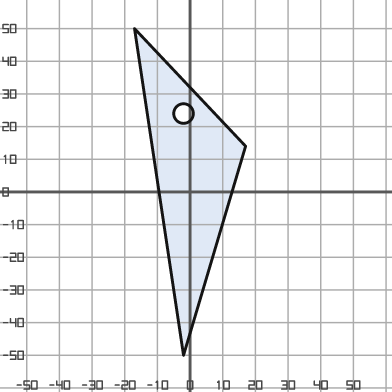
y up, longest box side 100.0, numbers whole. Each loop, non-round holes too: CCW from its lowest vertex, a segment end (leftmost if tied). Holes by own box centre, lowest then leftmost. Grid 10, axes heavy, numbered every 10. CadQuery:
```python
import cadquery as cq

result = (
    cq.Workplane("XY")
    .moveTo(-2.0, -50.0)
    .lineTo(17.0, 14.0)
    .lineTo(-17.0, 50.0)
    .close()
    .moveTo(-2.0, 24.0)
    .circle(3.0)
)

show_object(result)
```